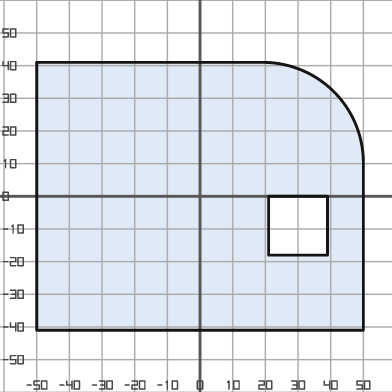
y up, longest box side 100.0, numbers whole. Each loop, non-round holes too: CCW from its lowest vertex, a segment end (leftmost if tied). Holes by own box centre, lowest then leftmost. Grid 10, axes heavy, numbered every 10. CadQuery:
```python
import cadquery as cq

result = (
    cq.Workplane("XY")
    .moveTo(-50.0, -41.0)
    .lineTo(50.0, -41.0)
    .lineTo(50.0, 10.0)
    .threePointArc((41.0, 32.0), (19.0, 41.0))
    .lineTo(-50.0, 41.0)
    .close()
    .moveTo(21.0, -18.0)
    .lineTo(39.0, -18.0)
    .lineTo(39.0, 0.0)
    .lineTo(21.0, 0.0)
    .close()
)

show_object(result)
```